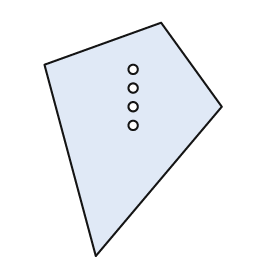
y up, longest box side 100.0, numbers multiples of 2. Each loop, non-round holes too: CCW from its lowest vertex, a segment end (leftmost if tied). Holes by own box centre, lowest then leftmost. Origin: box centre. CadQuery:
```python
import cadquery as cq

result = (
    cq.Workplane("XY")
    .moveTo(-16.0, -50.0)
    .lineTo(38.0, 14.0)
    .lineTo(12.0, 50.0)
    .lineTo(-38.0, 32.0)
    .close()
    .moveTo(0.0, 6.0)
    .circle(2.0)
    .moveTo(0.0, 14.0)
    .circle(2.0)
    .moveTo(0.0, 22.0)
    .circle(2.0)
    .moveTo(0.0, 30.0)
    .circle(2.0)
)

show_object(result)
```